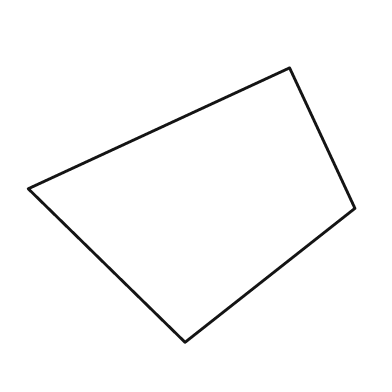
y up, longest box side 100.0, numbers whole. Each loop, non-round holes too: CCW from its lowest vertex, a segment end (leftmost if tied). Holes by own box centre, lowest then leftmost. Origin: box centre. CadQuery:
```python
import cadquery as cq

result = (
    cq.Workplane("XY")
    .moveTo(-2.0, -42.0)
    .lineTo(50.0, -1.0)
    .lineTo(30.0, 42.0)
    .lineTo(-50.0, 5.0)
    .close()
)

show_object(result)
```